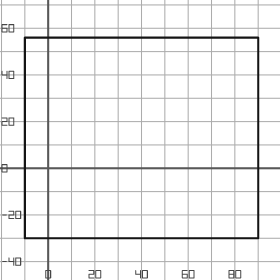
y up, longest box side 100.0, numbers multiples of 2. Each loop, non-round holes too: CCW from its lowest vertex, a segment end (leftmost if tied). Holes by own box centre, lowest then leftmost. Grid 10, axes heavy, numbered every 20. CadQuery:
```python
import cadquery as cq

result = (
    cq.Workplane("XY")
    .moveTo(-10.0, -30.0)
    .lineTo(90.0, -30.0)
    .lineTo(90.0, 56.0)
    .lineTo(-10.0, 56.0)
    .close()
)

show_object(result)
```